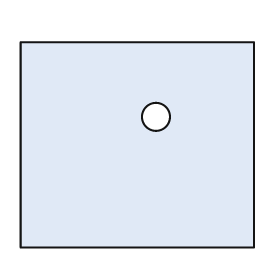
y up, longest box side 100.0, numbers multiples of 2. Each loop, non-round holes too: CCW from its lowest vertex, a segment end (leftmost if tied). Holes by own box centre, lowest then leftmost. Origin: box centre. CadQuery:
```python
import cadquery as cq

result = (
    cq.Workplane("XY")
    .moveTo(-50.0, -44.0)
    .lineTo(50.0, -44.0)
    .lineTo(50.0, 44.0)
    .lineTo(-50.0, 44.0)
    .close()
    .moveTo(8.0, 12.0)
    .circle(6.0)
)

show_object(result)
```